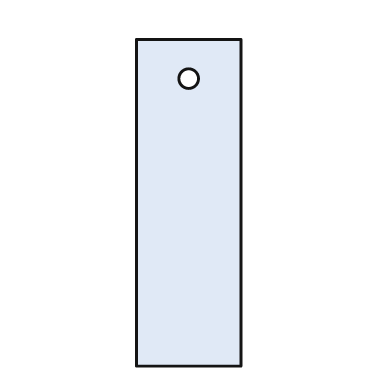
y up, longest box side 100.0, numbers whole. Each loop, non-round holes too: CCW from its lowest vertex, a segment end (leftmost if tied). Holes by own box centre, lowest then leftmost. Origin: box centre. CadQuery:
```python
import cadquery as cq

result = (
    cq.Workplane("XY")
    .moveTo(-16.0, -50.0)
    .lineTo(16.0, -50.0)
    .lineTo(16.0, 50.0)
    .lineTo(-16.0, 50.0)
    .close()
    .moveTo(0.0, 38.0)
    .circle(3.0)
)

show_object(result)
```